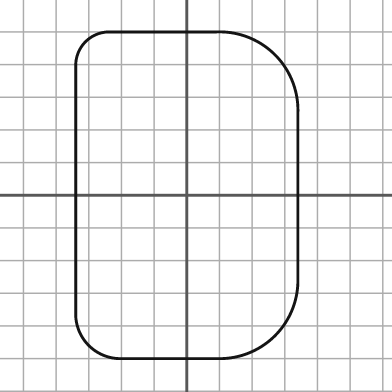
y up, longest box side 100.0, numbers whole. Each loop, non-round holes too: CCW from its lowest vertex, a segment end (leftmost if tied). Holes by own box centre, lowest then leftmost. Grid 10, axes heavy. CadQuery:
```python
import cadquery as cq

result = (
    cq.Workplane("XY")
    .moveTo(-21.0, -50.0)
    .lineTo(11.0, -50.0)
    .threePointArc((27.0, -43.0), (34.0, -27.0))
    .lineTo(34.0, 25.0)
    .threePointArc((27.0, 43.0), (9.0, 50.0))
    .lineTo(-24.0, 50.0)
    .threePointArc((-31.0, 47.0), (-34.0, 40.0))
    .lineTo(-34.0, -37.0)
    .threePointArc((-30.0, -46.0), (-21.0, -50.0))
    .close()
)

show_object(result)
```